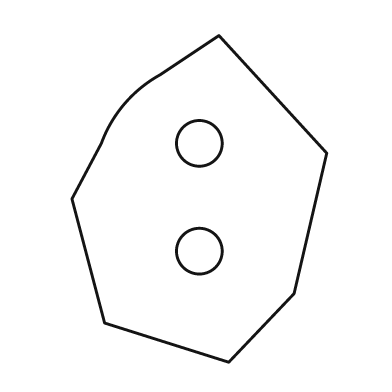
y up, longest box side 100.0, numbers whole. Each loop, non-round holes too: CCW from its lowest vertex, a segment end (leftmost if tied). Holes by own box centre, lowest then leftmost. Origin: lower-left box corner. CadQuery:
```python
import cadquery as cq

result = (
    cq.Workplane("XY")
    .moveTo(48.0, 0.0)
    .lineTo(68.0, 21.0)
    .lineTo(78.0, 64.0)
    .lineTo(45.0, 100.0)
    .lineTo(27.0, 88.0)
    .threePointArc((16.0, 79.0), (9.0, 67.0))
    .lineTo(0.0, 50.0)
    .lineTo(10.0, 12.0)
    .close()
    .moveTo(39.0, 34.0)
    .circle(7.0)
    .moveTo(39.0, 67.0)
    .circle(7.0)
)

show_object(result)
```